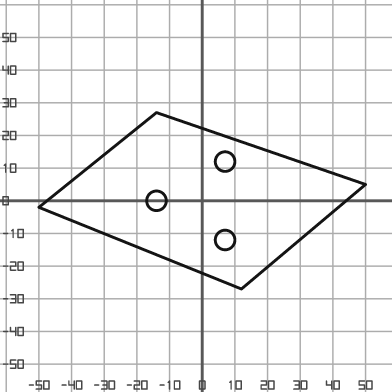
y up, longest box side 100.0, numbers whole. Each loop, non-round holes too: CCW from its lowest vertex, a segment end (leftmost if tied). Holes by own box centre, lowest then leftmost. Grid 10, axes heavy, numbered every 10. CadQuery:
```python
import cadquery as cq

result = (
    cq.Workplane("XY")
    .moveTo(12.0, -27.0)
    .lineTo(50.0, 5.0)
    .lineTo(-14.0, 27.0)
    .lineTo(-50.0, -2.0)
    .close()
    .moveTo(7.0, -12.0)
    .circle(3.0)
    .moveTo(-14.0, 0.0)
    .circle(3.0)
    .moveTo(7.0, 12.0)
    .circle(3.0)
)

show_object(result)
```